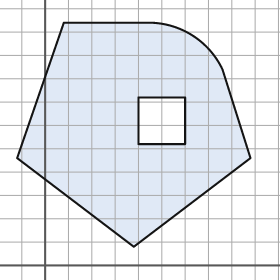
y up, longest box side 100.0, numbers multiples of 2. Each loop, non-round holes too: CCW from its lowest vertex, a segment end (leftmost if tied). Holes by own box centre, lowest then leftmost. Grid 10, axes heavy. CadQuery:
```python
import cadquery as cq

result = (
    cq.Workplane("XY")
    .moveTo(38.0, 8.0)
    .lineTo(88.0, 46.0)
    .lineTo(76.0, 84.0)
    .threePointArc((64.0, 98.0), (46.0, 104.0))
    .lineTo(8.0, 104.0)
    .lineTo(-12.0, 46.0)
    .close()
    .moveTo(40.0, 52.0)
    .lineTo(60.0, 52.0)
    .lineTo(60.0, 72.0)
    .lineTo(40.0, 72.0)
    .close()
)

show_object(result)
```